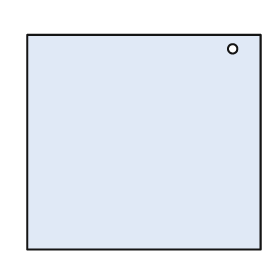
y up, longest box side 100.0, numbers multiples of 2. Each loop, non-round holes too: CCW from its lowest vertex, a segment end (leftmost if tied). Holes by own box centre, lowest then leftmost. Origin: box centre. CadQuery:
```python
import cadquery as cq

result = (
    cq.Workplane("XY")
    .moveTo(-50.0, -46.0)
    .lineTo(50.0, -46.0)
    .lineTo(50.0, 46.0)
    .lineTo(-50.0, 46.0)
    .close()
    .moveTo(38.0, 40.0)
    .circle(2.0)
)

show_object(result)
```